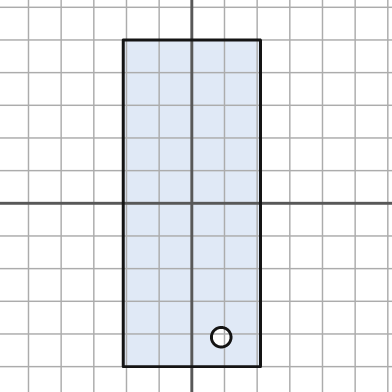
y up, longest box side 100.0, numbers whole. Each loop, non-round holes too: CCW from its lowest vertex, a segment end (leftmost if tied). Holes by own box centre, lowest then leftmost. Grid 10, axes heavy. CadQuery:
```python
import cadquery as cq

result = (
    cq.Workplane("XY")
    .moveTo(-21.0, -50.0)
    .lineTo(21.0, -50.0)
    .lineTo(21.0, 50.0)
    .lineTo(-21.0, 50.0)
    .close()
    .moveTo(9.0, -41.0)
    .circle(3.0)
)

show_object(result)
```